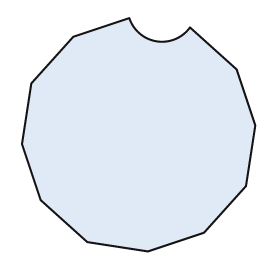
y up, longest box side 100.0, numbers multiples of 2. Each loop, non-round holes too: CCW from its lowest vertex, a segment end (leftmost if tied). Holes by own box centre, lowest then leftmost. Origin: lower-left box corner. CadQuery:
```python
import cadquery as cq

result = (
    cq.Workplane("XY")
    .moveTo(54.0, 0.0)
    .lineTo(78.0, 8.0)
    .lineTo(96.0, 28.0)
    .lineTo(100.0, 54.0)
    .lineTo(92.0, 78.0)
    .lineTo(72.0, 96.0)
    .threePointArc((58.0, 90.0), (46.0, 100.0))
    .lineTo(22.0, 92.0)
    .lineTo(4.0, 72.0)
    .lineTo(0.0, 46.0)
    .lineTo(8.0, 22.0)
    .lineTo(28.0, 4.0)
    .close()
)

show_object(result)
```